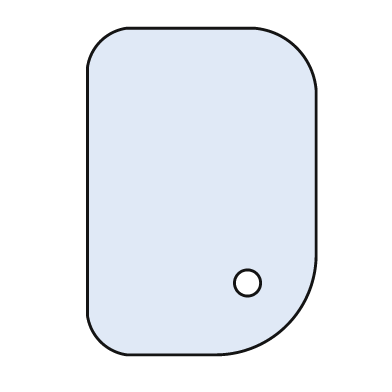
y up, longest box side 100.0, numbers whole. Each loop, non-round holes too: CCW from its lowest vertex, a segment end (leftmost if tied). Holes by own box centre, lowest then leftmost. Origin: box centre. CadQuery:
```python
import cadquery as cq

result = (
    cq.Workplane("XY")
    .moveTo(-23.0, -50.0)
    .lineTo(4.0, -50.0)
    .threePointArc((26.0, -41.0), (35.0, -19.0))
    .lineTo(35.0, 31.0)
    .threePointArc((29.0, 44.0), (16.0, 50.0))
    .lineTo(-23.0, 50.0)
    .threePointArc((-31.0, 46.0), (-35.0, 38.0))
    .lineTo(-35.0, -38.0)
    .threePointArc((-31.0, -46.0), (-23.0, -50.0))
    .close()
    .moveTo(14.0, -28.0)
    .circle(4.0)
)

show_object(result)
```